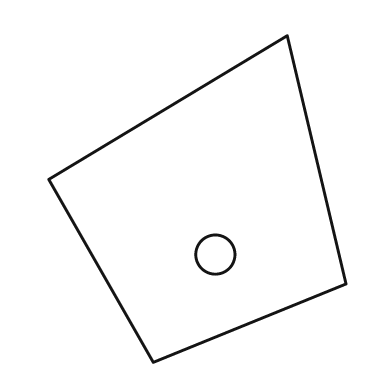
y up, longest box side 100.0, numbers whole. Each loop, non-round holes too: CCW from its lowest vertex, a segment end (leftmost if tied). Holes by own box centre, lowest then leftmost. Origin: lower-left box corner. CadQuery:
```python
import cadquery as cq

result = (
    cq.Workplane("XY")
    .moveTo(32.0, 0.0)
    .lineTo(91.0, 24.0)
    .lineTo(73.0, 100.0)
    .lineTo(0.0, 56.0)
    .close()
    .moveTo(51.0, 33.0)
    .circle(6.0)
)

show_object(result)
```